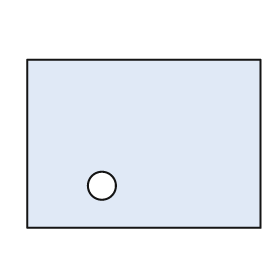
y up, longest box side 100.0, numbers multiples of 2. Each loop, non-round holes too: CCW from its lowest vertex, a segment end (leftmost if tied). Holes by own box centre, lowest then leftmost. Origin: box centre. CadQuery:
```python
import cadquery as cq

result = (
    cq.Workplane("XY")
    .moveTo(-50.0, -36.0)
    .lineTo(50.0, -36.0)
    .lineTo(50.0, 36.0)
    .lineTo(-50.0, 36.0)
    .close()
    .moveTo(-18.0, -18.0)
    .circle(6.0)
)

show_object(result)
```